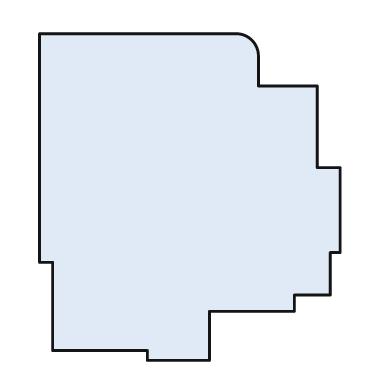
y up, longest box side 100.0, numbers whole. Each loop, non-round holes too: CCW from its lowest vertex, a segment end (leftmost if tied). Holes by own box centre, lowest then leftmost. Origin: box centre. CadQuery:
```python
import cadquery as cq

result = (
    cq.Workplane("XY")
    .moveTo(-13.0, -50.0)
    .lineTo(6.0, -50.0)
    .lineTo(6.0, -35.0)
    .lineTo(32.0, -35.0)
    .lineTo(32.0, -30.0)
    .lineTo(43.0, -30.0)
    .lineTo(43.0, -17.0)
    .lineTo(46.0, -17.0)
    .lineTo(46.0, 9.0)
    .lineTo(39.0, 9.0)
    .lineTo(39.0, 34.0)
    .lineTo(21.0, 34.0)
    .lineTo(21.0, 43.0)
    .threePointArc((19.0, 48.0), (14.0, 50.0))
    .lineTo(-46.0, 50.0)
    .lineTo(-46.0, -20.0)
    .lineTo(-42.0, -20.0)
    .lineTo(-42.0, -47.0)
    .lineTo(-13.0, -47.0)
    .close()
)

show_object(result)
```